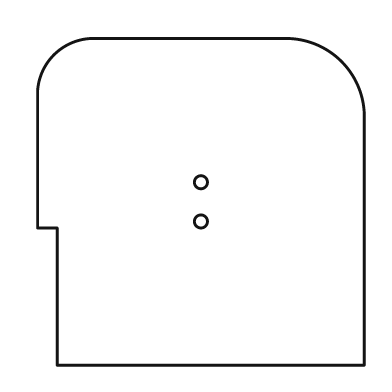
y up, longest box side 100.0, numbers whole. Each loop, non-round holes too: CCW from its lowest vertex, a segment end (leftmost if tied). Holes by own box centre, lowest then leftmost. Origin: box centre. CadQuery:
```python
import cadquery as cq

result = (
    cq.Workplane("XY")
    .moveTo(-44.0, -50.0)
    .lineTo(50.0, -50.0)
    .lineTo(50.0, 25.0)
    .threePointArc((43.0, 43.0), (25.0, 50.0))
    .lineTo(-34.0, 50.0)
    .threePointArc((-45.0, 45.0), (-50.0, 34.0))
    .lineTo(-50.0, -8.0)
    .lineTo(-44.0, -8.0)
    .close()
    .moveTo(0.0, -6.0)
    .circle(2.0)
    .moveTo(0.0, 6.0)
    .circle(2.0)
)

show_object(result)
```